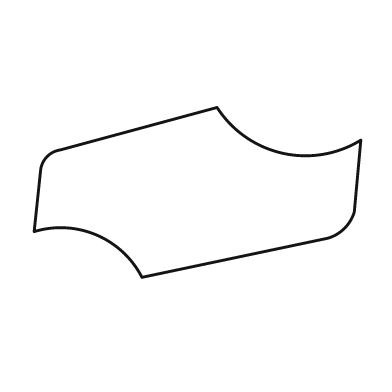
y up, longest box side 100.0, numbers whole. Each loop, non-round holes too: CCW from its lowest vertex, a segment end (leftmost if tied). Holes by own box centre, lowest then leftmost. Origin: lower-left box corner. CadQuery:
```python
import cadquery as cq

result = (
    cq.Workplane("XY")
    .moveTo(33.0, 0.0)
    .lineTo(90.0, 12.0)
    .threePointArc((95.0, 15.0), (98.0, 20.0))
    .lineTo(100.0, 42.0)
    .threePointArc((76.0, 38.0), (56.0, 52.0))
    .lineTo(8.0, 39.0)
    .threePointArc((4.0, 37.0), (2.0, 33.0))
    .lineTo(0.0, 14.0)
    .threePointArc((19.0, 13.0), (33.0, 0.0))
    .close()
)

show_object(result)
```